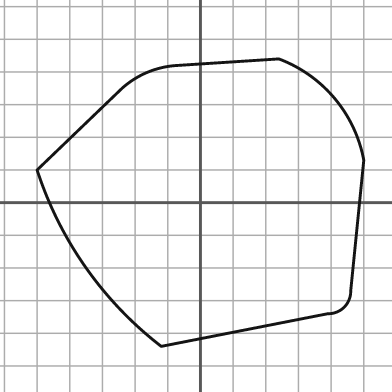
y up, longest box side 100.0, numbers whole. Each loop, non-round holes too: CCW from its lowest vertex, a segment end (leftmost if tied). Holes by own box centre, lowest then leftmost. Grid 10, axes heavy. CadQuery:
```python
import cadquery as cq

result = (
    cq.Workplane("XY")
    .moveTo(-12.0, -44.0)
    .lineTo(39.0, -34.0)
    .threePointArc((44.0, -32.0), (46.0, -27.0))
    .lineTo(50.0, 13.0)
    .threePointArc((41.0, 32.0), (24.0, 44.0))
    .lineTo(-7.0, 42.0)
    .threePointArc((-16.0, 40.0), (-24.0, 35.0))
    .lineTo(-50.0, 10.0)
    .threePointArc((-35.0, -20.0), (-12.0, -44.0))
    .close()
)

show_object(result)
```